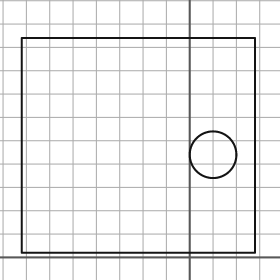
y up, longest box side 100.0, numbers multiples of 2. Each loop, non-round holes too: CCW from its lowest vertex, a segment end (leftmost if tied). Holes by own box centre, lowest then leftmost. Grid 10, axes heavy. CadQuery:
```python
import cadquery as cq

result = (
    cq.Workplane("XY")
    .moveTo(-72.0, 2.0)
    .lineTo(28.0, 2.0)
    .lineTo(28.0, 94.0)
    .lineTo(-72.0, 94.0)
    .close()
    .moveTo(10.0, 44.0)
    .circle(10.0)
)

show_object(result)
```